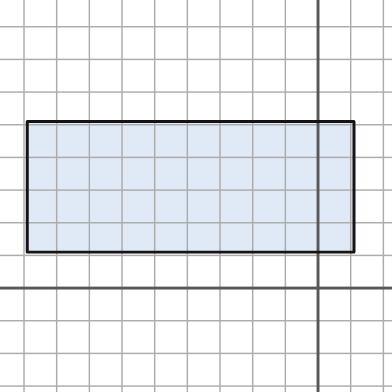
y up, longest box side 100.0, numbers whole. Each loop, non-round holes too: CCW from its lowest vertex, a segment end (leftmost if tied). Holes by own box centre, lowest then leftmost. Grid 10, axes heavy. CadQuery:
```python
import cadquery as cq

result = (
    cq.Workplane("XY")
    .moveTo(-89.0, 11.0)
    .lineTo(11.0, 11.0)
    .lineTo(11.0, 51.0)
    .lineTo(-89.0, 51.0)
    .close()
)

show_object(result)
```